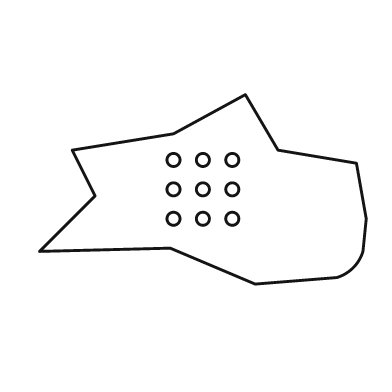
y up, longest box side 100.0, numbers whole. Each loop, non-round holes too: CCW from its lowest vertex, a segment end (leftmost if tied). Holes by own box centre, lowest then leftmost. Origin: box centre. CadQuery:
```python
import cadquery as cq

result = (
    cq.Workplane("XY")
    .moveTo(16.0, -29.0)
    .lineTo(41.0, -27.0)
    .threePointArc((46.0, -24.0), (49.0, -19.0))
    .lineTo(50.0, -9.0)
    .lineTo(47.0, 8.0)
    .lineTo(23.0, 12.0)
    .lineTo(13.0, 29.0)
    .lineTo(-9.0, 17.0)
    .lineTo(-40.0, 12.0)
    .lineTo(-33.0, -2.0)
    .lineTo(-50.0, -19.0)
    .lineTo(-10.0, -18.0)
    .close()
    .moveTo(-9.0, -9.0)
    .circle(2.0)
    .moveTo(0.0, -9.0)
    .circle(2.0)
    .moveTo(9.0, -9.0)
    .circle(2.0)
    .moveTo(-9.0, 0.0)
    .circle(2.0)
    .moveTo(0.0, 0.0)
    .circle(2.0)
    .moveTo(9.0, 0.0)
    .circle(2.0)
    .moveTo(-9.0, 9.0)
    .circle(2.0)
    .moveTo(0.0, 9.0)
    .circle(2.0)
    .moveTo(9.0, 9.0)
    .circle(2.0)
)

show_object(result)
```